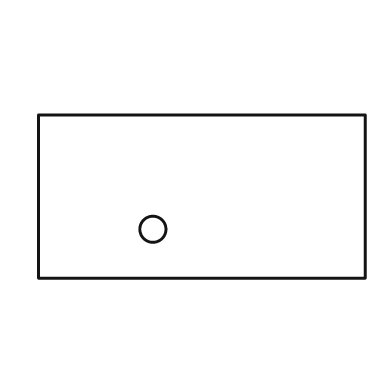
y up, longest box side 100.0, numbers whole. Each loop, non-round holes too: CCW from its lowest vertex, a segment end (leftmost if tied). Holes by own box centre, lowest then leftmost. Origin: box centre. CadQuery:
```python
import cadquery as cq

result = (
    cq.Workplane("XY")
    .moveTo(-50.0, -25.0)
    .lineTo(50.0, -25.0)
    .lineTo(50.0, 25.0)
    .lineTo(-50.0, 25.0)
    .close()
    .moveTo(-15.0, -10.0)
    .circle(4.0)
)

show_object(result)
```